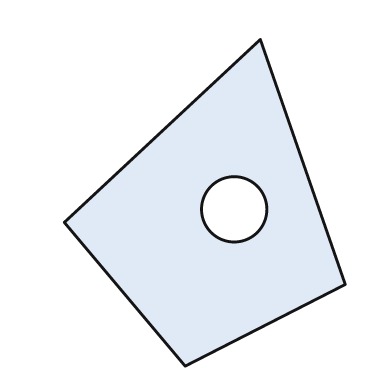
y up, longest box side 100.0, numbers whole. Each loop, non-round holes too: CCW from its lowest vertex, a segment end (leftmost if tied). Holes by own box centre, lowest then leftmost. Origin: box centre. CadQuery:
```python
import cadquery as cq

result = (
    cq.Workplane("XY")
    .moveTo(-6.0, -50.0)
    .lineTo(43.0, -25.0)
    .lineTo(17.0, 50.0)
    .lineTo(-43.0, -6.0)
    .close()
    .moveTo(9.0, -2.0)
    .circle(10.0)
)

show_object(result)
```